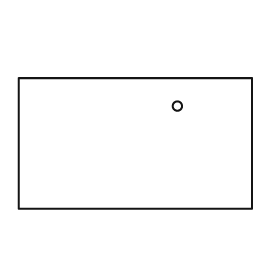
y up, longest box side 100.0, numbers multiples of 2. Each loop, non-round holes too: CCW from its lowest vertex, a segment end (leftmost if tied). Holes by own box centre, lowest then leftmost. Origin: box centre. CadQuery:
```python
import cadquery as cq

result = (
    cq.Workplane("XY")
    .moveTo(-50.0, -28.0)
    .lineTo(50.0, -28.0)
    .lineTo(50.0, 28.0)
    .lineTo(-50.0, 28.0)
    .close()
    .moveTo(18.0, 16.0)
    .circle(2.0)
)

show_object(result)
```